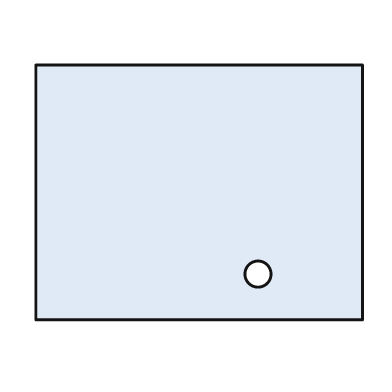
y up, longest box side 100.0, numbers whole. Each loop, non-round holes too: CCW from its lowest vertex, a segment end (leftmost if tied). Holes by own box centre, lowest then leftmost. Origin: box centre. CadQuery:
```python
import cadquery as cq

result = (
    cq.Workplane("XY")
    .moveTo(-50.0, -39.0)
    .lineTo(50.0, -39.0)
    .lineTo(50.0, 39.0)
    .lineTo(-50.0, 39.0)
    .close()
    .moveTo(18.0, -25.0)
    .circle(4.0)
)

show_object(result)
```